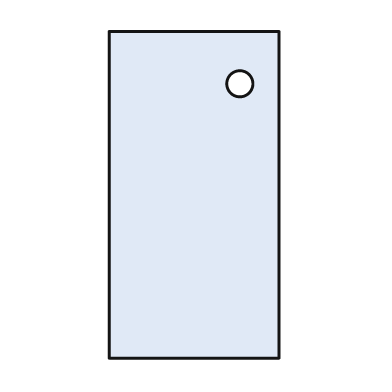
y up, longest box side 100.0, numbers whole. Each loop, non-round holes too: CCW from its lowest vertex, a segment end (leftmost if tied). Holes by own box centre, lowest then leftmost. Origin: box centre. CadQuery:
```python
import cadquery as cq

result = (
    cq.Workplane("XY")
    .moveTo(-26.0, -50.0)
    .lineTo(26.0, -50.0)
    .lineTo(26.0, 50.0)
    .lineTo(-26.0, 50.0)
    .close()
    .moveTo(14.0, 34.0)
    .circle(4.0)
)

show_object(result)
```